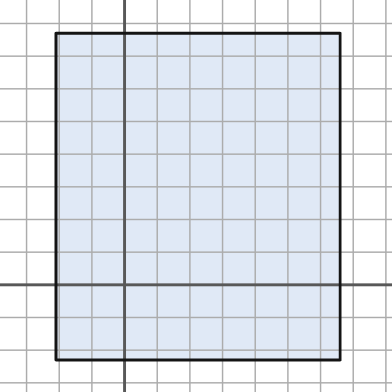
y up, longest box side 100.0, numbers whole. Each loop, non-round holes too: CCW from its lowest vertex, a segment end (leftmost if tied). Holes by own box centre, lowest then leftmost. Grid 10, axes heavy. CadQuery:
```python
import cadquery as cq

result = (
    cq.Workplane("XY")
    .moveTo(-21.0, -23.0)
    .lineTo(66.0, -23.0)
    .lineTo(66.0, 77.0)
    .lineTo(-21.0, 77.0)
    .close()
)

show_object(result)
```